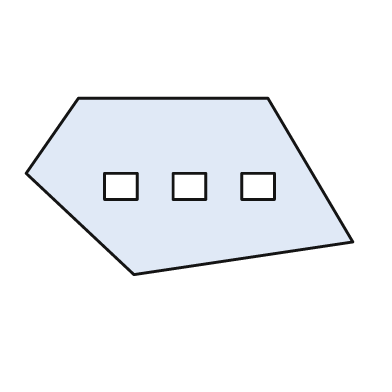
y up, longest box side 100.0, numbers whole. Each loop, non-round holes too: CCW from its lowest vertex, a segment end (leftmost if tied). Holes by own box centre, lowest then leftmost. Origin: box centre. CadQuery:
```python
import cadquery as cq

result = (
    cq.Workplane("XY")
    .moveTo(-17.0, -27.0)
    .lineTo(50.0, -17.0)
    .lineTo(24.0, 27.0)
    .lineTo(-34.0, 27.0)
    .lineTo(-50.0, 4.0)
    .close()
    .moveTo(-26.0, -4.0)
    .lineTo(-16.0, -4.0)
    .lineTo(-16.0, 4.0)
    .lineTo(-26.0, 4.0)
    .close()
    .moveTo(-5.0, -4.0)
    .lineTo(5.0, -4.0)
    .lineTo(5.0, 4.0)
    .lineTo(-5.0, 4.0)
    .close()
    .moveTo(16.0, -4.0)
    .lineTo(26.0, -4.0)
    .lineTo(26.0, 4.0)
    .lineTo(16.0, 4.0)
    .close()
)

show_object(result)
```